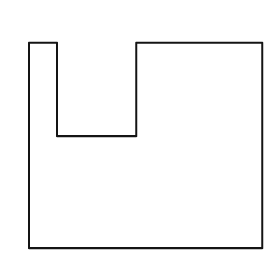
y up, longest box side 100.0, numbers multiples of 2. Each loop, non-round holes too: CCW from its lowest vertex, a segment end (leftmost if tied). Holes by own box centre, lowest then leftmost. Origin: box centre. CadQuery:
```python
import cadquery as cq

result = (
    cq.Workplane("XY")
    .moveTo(-50.0, -44.0)
    .lineTo(50.0, -44.0)
    .lineTo(50.0, 44.0)
    .lineTo(-4.0, 44.0)
    .lineTo(-4.0, 4.0)
    .lineTo(-38.0, 4.0)
    .lineTo(-38.0, 44.0)
    .lineTo(-50.0, 44.0)
    .close()
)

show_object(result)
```